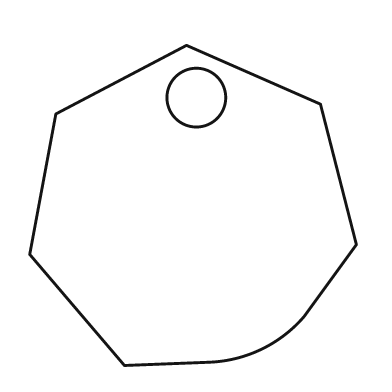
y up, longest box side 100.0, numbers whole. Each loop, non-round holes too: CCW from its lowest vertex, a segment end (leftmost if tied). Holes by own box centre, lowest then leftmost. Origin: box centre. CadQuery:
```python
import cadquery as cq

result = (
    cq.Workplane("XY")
    .moveTo(-21.0, -49.0)
    .lineTo(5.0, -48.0)
    .threePointArc((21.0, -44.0), (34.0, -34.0))
    .lineTo(50.0, -12.0)
    .lineTo(39.0, 31.0)
    .lineTo(-2.0, 49.0)
    .lineTo(-42.0, 28.0)
    .lineTo(-50.0, -15.0)
    .close()
    .moveTo(1.0, 33.0)
    .circle(9.0)
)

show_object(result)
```